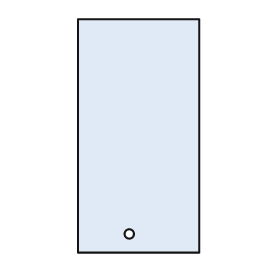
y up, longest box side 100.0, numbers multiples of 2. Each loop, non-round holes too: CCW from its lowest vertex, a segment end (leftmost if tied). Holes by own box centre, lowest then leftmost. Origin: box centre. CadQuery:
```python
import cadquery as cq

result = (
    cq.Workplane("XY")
    .moveTo(-26.0, -50.0)
    .lineTo(26.0, -50.0)
    .lineTo(26.0, 50.0)
    .lineTo(-26.0, 50.0)
    .close()
    .moveTo(-4.0, -42.0)
    .circle(2.0)
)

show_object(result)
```